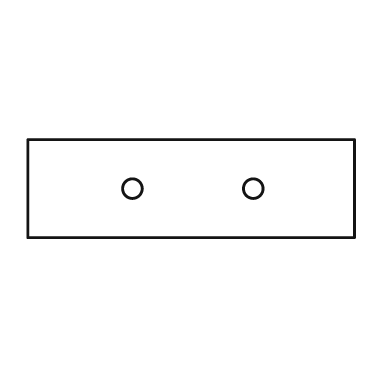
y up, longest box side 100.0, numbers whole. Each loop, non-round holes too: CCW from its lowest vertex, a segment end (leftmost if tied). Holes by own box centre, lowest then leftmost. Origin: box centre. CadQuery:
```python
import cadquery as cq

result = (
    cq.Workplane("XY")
    .moveTo(-50.0, -15.0)
    .lineTo(50.0, -15.0)
    .lineTo(50.0, 15.0)
    .lineTo(-50.0, 15.0)
    .close()
    .moveTo(-18.0, 0.0)
    .circle(3.0)
    .moveTo(19.0, 0.0)
    .circle(3.0)
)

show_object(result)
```